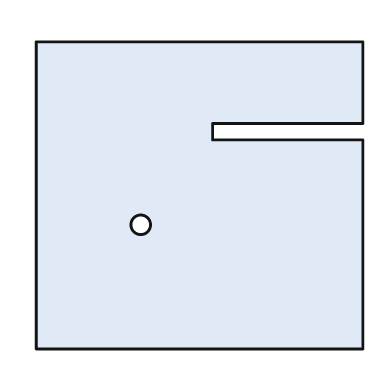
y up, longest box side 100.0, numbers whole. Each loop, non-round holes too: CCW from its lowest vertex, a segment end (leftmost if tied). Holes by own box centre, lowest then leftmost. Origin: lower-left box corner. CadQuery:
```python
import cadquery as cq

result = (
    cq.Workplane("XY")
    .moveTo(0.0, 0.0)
    .lineTo(100.0, 0.0)
    .lineTo(100.0, 64.0)
    .lineTo(54.0, 64.0)
    .lineTo(54.0, 69.0)
    .lineTo(100.0, 69.0)
    .lineTo(100.0, 94.0)
    .lineTo(0.0, 94.0)
    .close()
    .moveTo(32.0, 38.0)
    .circle(3.0)
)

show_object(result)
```